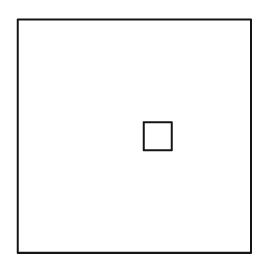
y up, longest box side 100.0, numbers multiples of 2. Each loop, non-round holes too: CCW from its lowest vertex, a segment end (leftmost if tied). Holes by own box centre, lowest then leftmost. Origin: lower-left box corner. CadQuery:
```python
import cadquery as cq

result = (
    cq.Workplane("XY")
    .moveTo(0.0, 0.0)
    .lineTo(100.0, 0.0)
    .lineTo(100.0, 100.0)
    .lineTo(0.0, 100.0)
    .close()
    .moveTo(54.0, 44.0)
    .lineTo(66.0, 44.0)
    .lineTo(66.0, 56.0)
    .lineTo(54.0, 56.0)
    .close()
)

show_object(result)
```